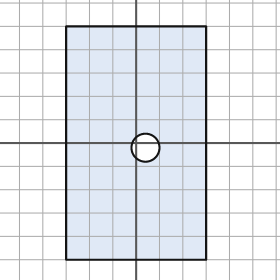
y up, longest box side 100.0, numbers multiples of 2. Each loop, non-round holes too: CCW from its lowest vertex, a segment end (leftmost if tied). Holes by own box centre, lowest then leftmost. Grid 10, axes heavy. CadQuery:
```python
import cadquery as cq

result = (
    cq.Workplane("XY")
    .moveTo(-30.0, -50.0)
    .lineTo(30.0, -50.0)
    .lineTo(30.0, 50.0)
    .lineTo(-30.0, 50.0)
    .close()
    .moveTo(4.0, -2.0)
    .circle(6.0)
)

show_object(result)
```